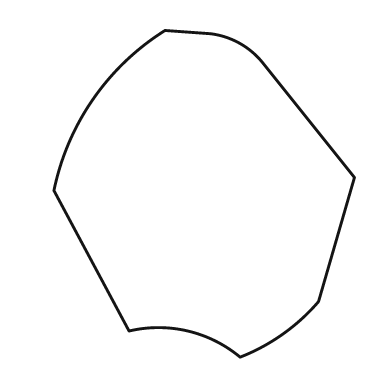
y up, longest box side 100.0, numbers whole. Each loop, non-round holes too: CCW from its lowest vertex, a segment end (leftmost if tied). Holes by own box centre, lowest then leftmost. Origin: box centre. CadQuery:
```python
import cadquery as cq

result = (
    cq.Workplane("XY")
    .moveTo(11.0, -50.0)
    .threePointArc((24.0, -43.0), (35.0, -33.0))
    .lineTo(46.0, 5.0)
    .lineTo(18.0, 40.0)
    .threePointArc((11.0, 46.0), (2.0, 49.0))
    .lineTo(-12.0, 50.0)
    .threePointArc((-34.0, 29.0), (-46.0, 1.0))
    .lineTo(-23.0, -42.0)
    .threePointArc((-5.0, -42.0), (11.0, -50.0))
    .close()
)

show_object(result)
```